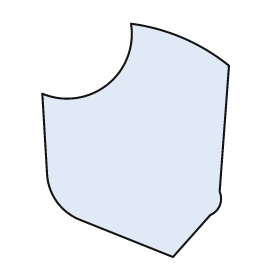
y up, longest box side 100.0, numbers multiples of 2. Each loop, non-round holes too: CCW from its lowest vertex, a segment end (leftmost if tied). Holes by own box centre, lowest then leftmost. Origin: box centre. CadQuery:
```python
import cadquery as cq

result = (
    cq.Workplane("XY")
    .moveTo(16.0, -50.0)
    .lineTo(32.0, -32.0)
    .threePointArc((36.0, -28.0), (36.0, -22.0))
    .lineTo(40.0, 32.0)
    .threePointArc((20.0, 44.0), (-2.0, 50.0))
    .threePointArc((-12.0, 24.0), (-40.0, 20.0))
    .lineTo(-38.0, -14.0)
    .threePointArc((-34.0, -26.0), (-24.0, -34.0))
    .close()
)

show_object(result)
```